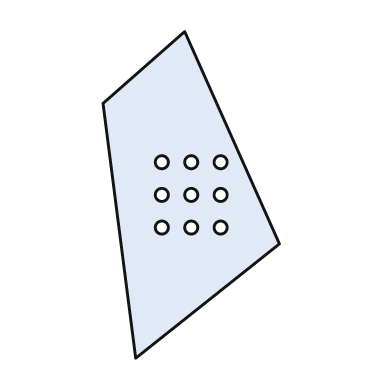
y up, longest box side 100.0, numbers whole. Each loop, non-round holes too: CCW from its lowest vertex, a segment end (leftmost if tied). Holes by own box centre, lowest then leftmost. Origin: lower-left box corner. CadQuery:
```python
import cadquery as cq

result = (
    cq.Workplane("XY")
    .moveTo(10.0, 0.0)
    .lineTo(54.0, 35.0)
    .lineTo(25.0, 100.0)
    .lineTo(0.0, 78.0)
    .close()
    .moveTo(18.0, 40.0)
    .circle(2.0)
    .moveTo(27.0, 40.0)
    .circle(2.0)
    .moveTo(36.0, 40.0)
    .circle(2.0)
    .moveTo(18.0, 50.0)
    .circle(2.0)
    .moveTo(27.0, 50.0)
    .circle(2.0)
    .moveTo(36.0, 50.0)
    .circle(2.0)
    .moveTo(18.0, 60.0)
    .circle(2.0)
    .moveTo(27.0, 60.0)
    .circle(2.0)
    .moveTo(36.0, 60.0)
    .circle(2.0)
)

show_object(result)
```